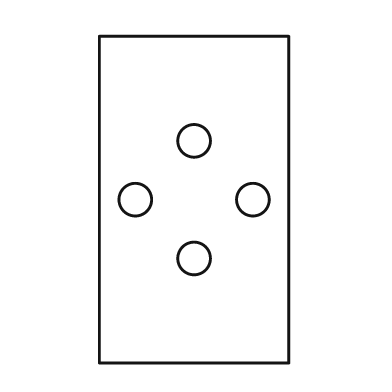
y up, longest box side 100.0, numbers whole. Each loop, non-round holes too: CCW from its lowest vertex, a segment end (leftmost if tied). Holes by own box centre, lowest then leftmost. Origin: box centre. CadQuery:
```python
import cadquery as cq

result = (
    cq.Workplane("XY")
    .moveTo(-29.0, -50.0)
    .lineTo(29.0, -50.0)
    .lineTo(29.0, 50.0)
    .lineTo(-29.0, 50.0)
    .close()
    .moveTo(0.0, -18.0)
    .circle(5.0)
    .moveTo(-18.0, 0.0)
    .circle(5.0)
    .moveTo(18.0, 0.0)
    .circle(5.0)
    .moveTo(0.0, 18.0)
    .circle(5.0)
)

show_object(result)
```